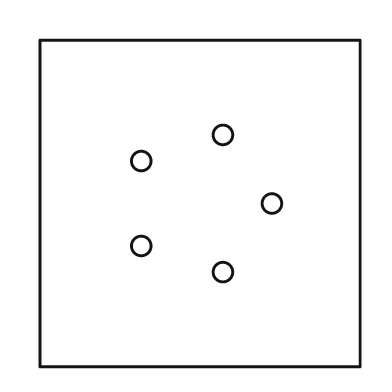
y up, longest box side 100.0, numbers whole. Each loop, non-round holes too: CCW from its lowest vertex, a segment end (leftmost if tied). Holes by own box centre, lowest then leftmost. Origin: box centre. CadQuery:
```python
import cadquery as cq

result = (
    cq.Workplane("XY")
    .moveTo(-49.0, -50.0)
    .lineTo(49.0, -50.0)
    .lineTo(49.0, 50.0)
    .lineTo(-49.0, 50.0)
    .close()
    .moveTo(7.0, -21.0)
    .circle(3.0)
    .moveTo(-18.0, -13.0)
    .circle(3.0)
    .moveTo(22.0, 0.0)
    .circle(3.0)
    .moveTo(-18.0, 13.0)
    .circle(3.0)
    .moveTo(7.0, 21.0)
    .circle(3.0)
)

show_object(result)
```